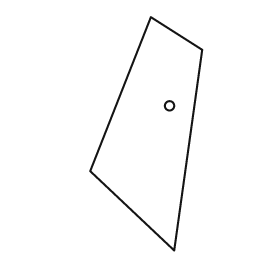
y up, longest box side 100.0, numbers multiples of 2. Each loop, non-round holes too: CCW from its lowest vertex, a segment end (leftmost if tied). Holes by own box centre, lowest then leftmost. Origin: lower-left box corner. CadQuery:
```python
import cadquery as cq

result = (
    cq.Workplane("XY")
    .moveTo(36.0, 0.0)
    .lineTo(48.0, 86.0)
    .lineTo(26.0, 100.0)
    .lineTo(0.0, 34.0)
    .close()
    .moveTo(34.0, 62.0)
    .circle(2.0)
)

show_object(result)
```